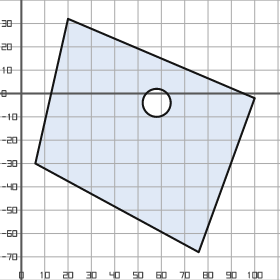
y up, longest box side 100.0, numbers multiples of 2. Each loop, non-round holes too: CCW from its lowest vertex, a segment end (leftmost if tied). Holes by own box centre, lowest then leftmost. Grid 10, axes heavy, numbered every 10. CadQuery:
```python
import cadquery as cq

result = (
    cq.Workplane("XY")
    .moveTo(76.0, -68.0)
    .lineTo(100.0, -2.0)
    .lineTo(20.0, 32.0)
    .lineTo(6.0, -30.0)
    .close()
    .moveTo(58.0, -4.0)
    .circle(6.0)
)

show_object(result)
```